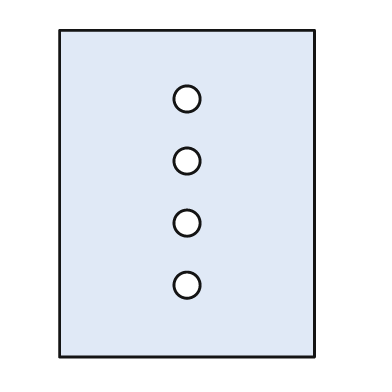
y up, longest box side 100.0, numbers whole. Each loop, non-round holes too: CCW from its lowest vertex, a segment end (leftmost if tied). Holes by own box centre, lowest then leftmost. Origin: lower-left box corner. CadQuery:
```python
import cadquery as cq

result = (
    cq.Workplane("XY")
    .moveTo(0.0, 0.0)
    .lineTo(78.0, 0.0)
    .lineTo(78.0, 100.0)
    .lineTo(0.0, 100.0)
    .close()
    .moveTo(39.0, 22.0)
    .circle(4.0)
    .moveTo(39.0, 41.0)
    .circle(4.0)
    .moveTo(39.0, 60.0)
    .circle(4.0)
    .moveTo(39.0, 79.0)
    .circle(4.0)
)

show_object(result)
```